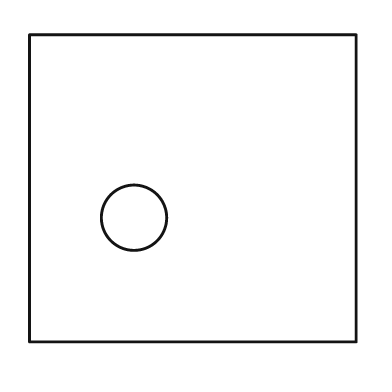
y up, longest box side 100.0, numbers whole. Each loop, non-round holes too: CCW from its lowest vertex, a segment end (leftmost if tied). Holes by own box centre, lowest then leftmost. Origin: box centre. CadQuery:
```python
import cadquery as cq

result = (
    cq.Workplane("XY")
    .moveTo(-50.0, -47.0)
    .lineTo(50.0, -47.0)
    .lineTo(50.0, 47.0)
    .lineTo(-50.0, 47.0)
    .close()
    .moveTo(-18.0, -9.0)
    .circle(10.0)
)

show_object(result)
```